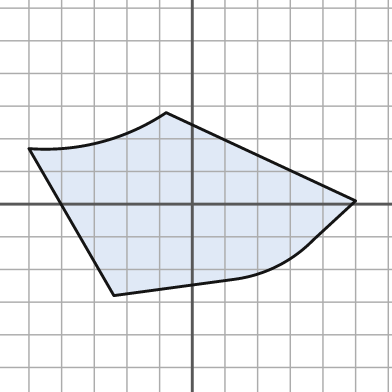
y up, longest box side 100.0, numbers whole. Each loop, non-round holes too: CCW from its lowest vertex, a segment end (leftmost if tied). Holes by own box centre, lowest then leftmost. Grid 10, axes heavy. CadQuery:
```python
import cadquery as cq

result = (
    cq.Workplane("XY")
    .moveTo(-24.0, -28.0)
    .lineTo(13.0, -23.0)
    .threePointArc((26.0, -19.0), (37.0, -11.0))
    .lineTo(50.0, 1.0)
    .lineTo(-8.0, 28.0)
    .threePointArc((-28.0, 19.0), (-50.0, 17.0))
    .close()
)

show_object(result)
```